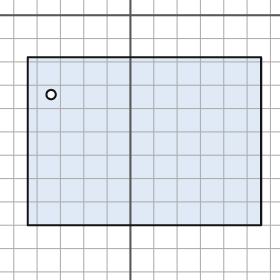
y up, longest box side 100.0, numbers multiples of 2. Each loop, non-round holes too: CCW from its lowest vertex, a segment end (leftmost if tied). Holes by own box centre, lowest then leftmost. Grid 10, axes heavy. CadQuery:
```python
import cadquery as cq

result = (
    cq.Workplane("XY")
    .moveTo(-44.0, -90.0)
    .lineTo(56.0, -90.0)
    .lineTo(56.0, -18.0)
    .lineTo(-44.0, -18.0)
    .close()
    .moveTo(-34.0, -34.0)
    .circle(2.0)
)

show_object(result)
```